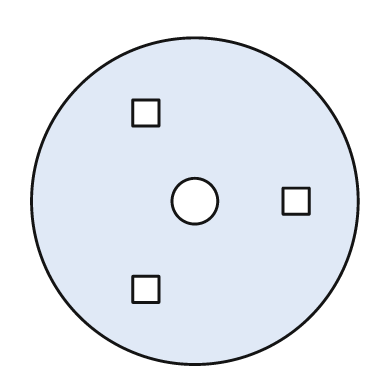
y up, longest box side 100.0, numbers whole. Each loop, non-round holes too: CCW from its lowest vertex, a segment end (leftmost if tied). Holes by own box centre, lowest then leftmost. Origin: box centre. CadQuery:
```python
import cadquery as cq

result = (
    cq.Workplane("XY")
    .moveTo(0.0, 0.0)
    .circle(50.0)
    .moveTo(-19.0, -31.0)
    .lineTo(-11.0, -31.0)
    .lineTo(-11.0, -23.0)
    .lineTo(-19.0, -23.0)
    .close()
    .moveTo(0.0, 0.0)
    .circle(7.0)
    .moveTo(27.0, -4.0)
    .lineTo(35.0, -4.0)
    .lineTo(35.0, 4.0)
    .lineTo(27.0, 4.0)
    .close()
    .moveTo(-19.0, 23.0)
    .lineTo(-11.0, 23.0)
    .lineTo(-11.0, 31.0)
    .lineTo(-19.0, 31.0)
    .close()
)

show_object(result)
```